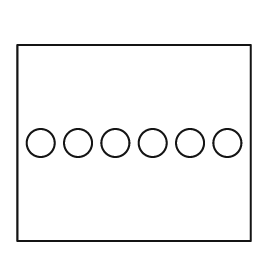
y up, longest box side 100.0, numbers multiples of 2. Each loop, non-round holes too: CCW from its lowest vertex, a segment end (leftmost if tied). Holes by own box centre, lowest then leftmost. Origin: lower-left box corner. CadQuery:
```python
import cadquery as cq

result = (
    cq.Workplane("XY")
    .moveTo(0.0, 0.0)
    .lineTo(100.0, 0.0)
    .lineTo(100.0, 84.0)
    .lineTo(0.0, 84.0)
    .close()
    .moveTo(10.0, 42.0)
    .circle(6.0)
    .moveTo(26.0, 42.0)
    .circle(6.0)
    .moveTo(42.0, 42.0)
    .circle(6.0)
    .moveTo(58.0, 42.0)
    .circle(6.0)
    .moveTo(74.0, 42.0)
    .circle(6.0)
    .moveTo(90.0, 42.0)
    .circle(6.0)
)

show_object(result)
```